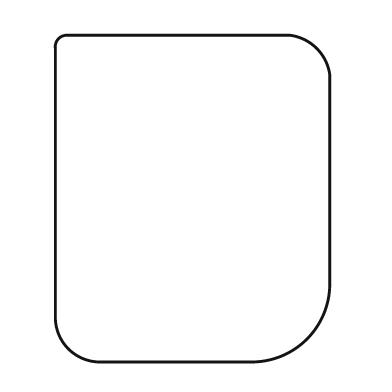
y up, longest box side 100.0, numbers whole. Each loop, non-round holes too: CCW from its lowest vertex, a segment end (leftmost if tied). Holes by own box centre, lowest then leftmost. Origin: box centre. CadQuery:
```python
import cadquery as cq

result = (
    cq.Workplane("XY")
    .moveTo(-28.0, -50.0)
    .lineTo(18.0, -50.0)
    .threePointArc((35.0, -43.0), (42.0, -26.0))
    .lineTo(42.0, 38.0)
    .threePointArc((38.0, 46.0), (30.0, 50.0))
    .lineTo(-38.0, 50.0)
    .threePointArc((-41.0, 49.0), (-42.0, 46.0))
    .lineTo(-42.0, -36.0)
    .threePointArc((-38.0, -46.0), (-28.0, -50.0))
    .close()
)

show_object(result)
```